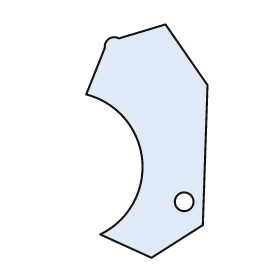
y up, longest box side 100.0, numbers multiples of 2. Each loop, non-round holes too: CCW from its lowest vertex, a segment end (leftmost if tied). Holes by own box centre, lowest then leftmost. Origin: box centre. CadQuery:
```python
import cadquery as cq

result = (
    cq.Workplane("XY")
    .moveTo(2.0, -50.0)
    .lineTo(24.0, -36.0)
    .lineTo(26.0, 24.0)
    .lineTo(8.0, 50.0)
    .lineTo(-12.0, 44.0)
    .threePointArc((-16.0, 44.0), (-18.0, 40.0))
    .lineTo(-26.0, 20.0)
    .threePointArc((-2.0, -8.0), (-20.0, -40.0))
    .close()
    .moveTo(16.0, -26.0)
    .circle(4.0)
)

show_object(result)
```